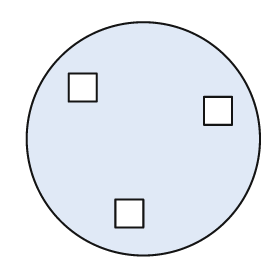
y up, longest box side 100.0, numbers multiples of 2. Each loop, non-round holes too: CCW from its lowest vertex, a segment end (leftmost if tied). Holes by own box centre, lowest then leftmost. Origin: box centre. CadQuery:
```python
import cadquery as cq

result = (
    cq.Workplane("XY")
    .moveTo(0.0, 0.0)
    .circle(50.0)
    .moveTo(-12.0, -38.0)
    .lineTo(0.0, -38.0)
    .lineTo(0.0, -26.0)
    .lineTo(-12.0, -26.0)
    .close()
    .moveTo(26.0, 6.0)
    .lineTo(38.0, 6.0)
    .lineTo(38.0, 18.0)
    .lineTo(26.0, 18.0)
    .close()
    .moveTo(-32.0, 16.0)
    .lineTo(-20.0, 16.0)
    .lineTo(-20.0, 28.0)
    .lineTo(-32.0, 28.0)
    .close()
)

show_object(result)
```